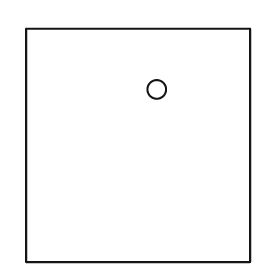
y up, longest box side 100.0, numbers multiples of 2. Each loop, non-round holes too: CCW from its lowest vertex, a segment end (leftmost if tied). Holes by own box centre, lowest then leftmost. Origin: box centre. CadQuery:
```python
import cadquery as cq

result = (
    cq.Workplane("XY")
    .moveTo(-48.0, -50.0)
    .lineTo(48.0, -50.0)
    .lineTo(48.0, 50.0)
    .lineTo(-48.0, 50.0)
    .close()
    .moveTo(8.0, 24.0)
    .circle(4.0)
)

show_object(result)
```